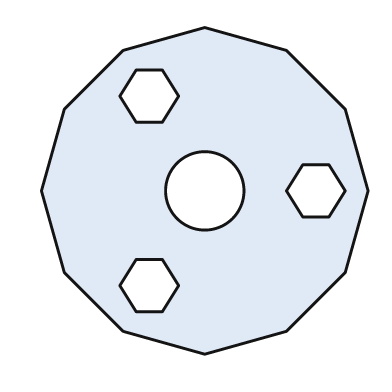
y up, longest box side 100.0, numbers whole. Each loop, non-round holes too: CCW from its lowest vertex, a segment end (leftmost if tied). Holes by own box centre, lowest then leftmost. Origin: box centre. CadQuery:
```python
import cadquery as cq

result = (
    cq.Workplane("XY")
    .moveTo(0.0, -50.0)
    .lineTo(25.0, -43.0)
    .lineTo(43.0, -25.0)
    .lineTo(50.0, 0.0)
    .lineTo(43.0, 25.0)
    .lineTo(25.0, 43.0)
    .lineTo(0.0, 50.0)
    .lineTo(-25.0, 43.0)
    .lineTo(-43.0, 25.0)
    .lineTo(-50.0, 0.0)
    .lineTo(-43.0, -25.0)
    .lineTo(-25.0, -43.0)
    .close()
    .moveTo(-21.0, -37.0)
    .lineTo(-13.0, -37.0)
    .lineTo(-8.0, -29.0)
    .lineTo(-13.0, -21.0)
    .lineTo(-21.0, -21.0)
    .lineTo(-26.0, -29.0)
    .close()
    .moveTo(0.0, 0.0)
    .circle(12.0)
    .moveTo(30.0, -8.0)
    .lineTo(38.0, -8.0)
    .lineTo(43.0, 0.0)
    .lineTo(38.0, 8.0)
    .lineTo(30.0, 8.0)
    .lineTo(25.0, 0.0)
    .close()
    .moveTo(-21.0, 21.0)
    .lineTo(-13.0, 21.0)
    .lineTo(-8.0, 29.0)
    .lineTo(-13.0, 37.0)
    .lineTo(-21.0, 37.0)
    .lineTo(-26.0, 29.0)
    .close()
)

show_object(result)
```